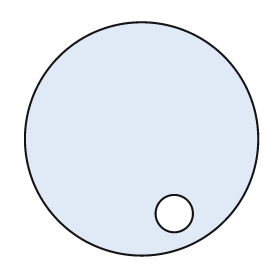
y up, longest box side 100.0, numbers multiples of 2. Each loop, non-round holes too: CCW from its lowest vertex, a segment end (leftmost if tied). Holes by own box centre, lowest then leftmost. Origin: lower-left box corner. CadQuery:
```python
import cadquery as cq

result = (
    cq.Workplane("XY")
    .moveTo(50.0, 50.0)
    .circle(50.0)
    .moveTo(64.0, 18.0)
    .circle(8.0)
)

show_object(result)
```